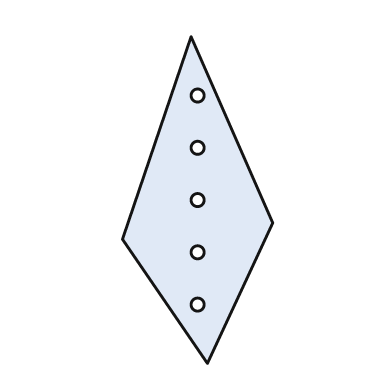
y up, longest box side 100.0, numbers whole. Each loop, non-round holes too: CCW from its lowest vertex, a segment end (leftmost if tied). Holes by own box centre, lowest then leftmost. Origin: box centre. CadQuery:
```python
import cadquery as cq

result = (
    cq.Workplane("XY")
    .moveTo(3.0, -50.0)
    .lineTo(23.0, -7.0)
    .lineTo(-2.0, 50.0)
    .lineTo(-23.0, -12.0)
    .close()
    .moveTo(0.0, -32.0)
    .circle(2.0)
    .moveTo(0.0, -16.0)
    .circle(2.0)
    .moveTo(0.0, 0.0)
    .circle(2.0)
    .moveTo(0.0, 16.0)
    .circle(2.0)
    .moveTo(0.0, 32.0)
    .circle(2.0)
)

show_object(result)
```